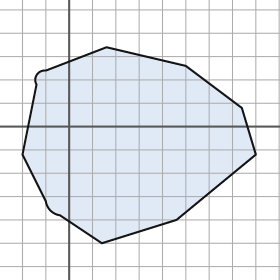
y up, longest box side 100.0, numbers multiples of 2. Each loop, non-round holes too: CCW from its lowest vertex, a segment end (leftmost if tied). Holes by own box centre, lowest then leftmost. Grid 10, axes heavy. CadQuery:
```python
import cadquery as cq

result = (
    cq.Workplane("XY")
    .moveTo(14.0, -50.0)
    .lineTo(46.0, -40.0)
    .lineTo(80.0, -12.0)
    .lineTo(74.0, 8.0)
    .lineTo(50.0, 26.0)
    .lineTo(16.0, 34.0)
    .lineTo(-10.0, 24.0)
    .threePointArc((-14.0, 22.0), (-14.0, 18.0))
    .lineTo(-20.0, -12.0)
    .lineTo(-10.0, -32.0)
    .threePointArc((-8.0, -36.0), (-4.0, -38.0))
    .close()
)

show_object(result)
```